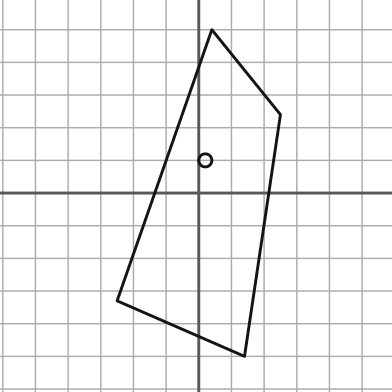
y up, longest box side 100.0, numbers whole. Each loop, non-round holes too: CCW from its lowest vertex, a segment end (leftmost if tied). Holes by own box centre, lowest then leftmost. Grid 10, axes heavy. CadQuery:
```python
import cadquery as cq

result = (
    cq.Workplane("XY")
    .moveTo(14.0, -50.0)
    .lineTo(25.0, 24.0)
    .lineTo(4.0, 50.0)
    .lineTo(-25.0, -33.0)
    .close()
    .moveTo(2.0, 10.0)
    .circle(2.0)
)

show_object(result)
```